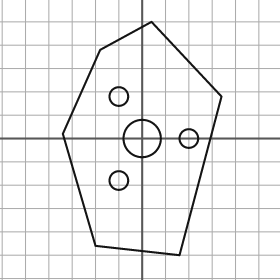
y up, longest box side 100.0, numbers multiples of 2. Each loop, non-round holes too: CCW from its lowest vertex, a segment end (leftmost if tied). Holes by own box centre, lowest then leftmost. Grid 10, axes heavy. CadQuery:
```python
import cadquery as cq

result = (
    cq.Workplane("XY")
    .moveTo(16.0, -50.0)
    .lineTo(34.0, 18.0)
    .lineTo(4.0, 50.0)
    .lineTo(-18.0, 38.0)
    .lineTo(-34.0, 2.0)
    .lineTo(-20.0, -46.0)
    .close()
    .moveTo(-10.0, -18.0)
    .circle(4.0)
    .moveTo(0.0, 0.0)
    .circle(8.0)
    .moveTo(20.0, 0.0)
    .circle(4.0)
    .moveTo(-10.0, 18.0)
    .circle(4.0)
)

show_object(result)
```